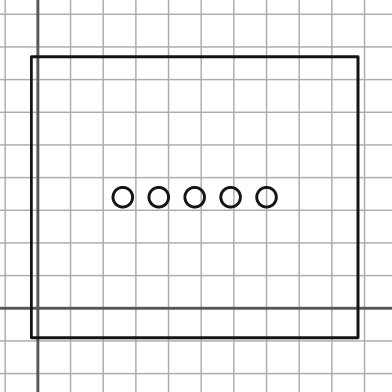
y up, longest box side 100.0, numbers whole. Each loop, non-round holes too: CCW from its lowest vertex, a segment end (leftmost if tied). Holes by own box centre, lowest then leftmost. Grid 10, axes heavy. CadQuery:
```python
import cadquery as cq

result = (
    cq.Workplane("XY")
    .moveTo(-2.0, -9.0)
    .lineTo(98.0, -9.0)
    .lineTo(98.0, 77.0)
    .lineTo(-2.0, 77.0)
    .close()
    .moveTo(26.0, 34.0)
    .circle(3.0)
    .moveTo(37.0, 34.0)
    .circle(3.0)
    .moveTo(48.0, 34.0)
    .circle(3.0)
    .moveTo(59.0, 34.0)
    .circle(3.0)
    .moveTo(70.0, 34.0)
    .circle(3.0)
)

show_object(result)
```